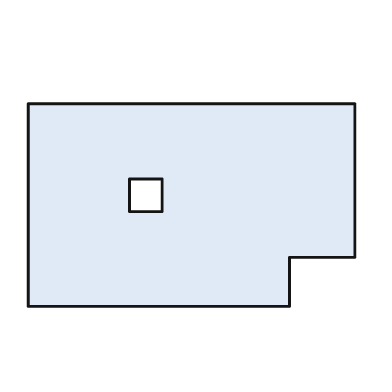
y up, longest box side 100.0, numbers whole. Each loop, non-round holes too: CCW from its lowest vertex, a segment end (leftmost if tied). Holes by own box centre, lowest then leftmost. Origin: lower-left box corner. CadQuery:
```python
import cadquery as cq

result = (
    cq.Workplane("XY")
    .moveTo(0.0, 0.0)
    .lineTo(80.0, 0.0)
    .lineTo(80.0, 15.0)
    .lineTo(100.0, 15.0)
    .lineTo(100.0, 62.0)
    .lineTo(0.0, 62.0)
    .close()
    .moveTo(31.0, 29.0)
    .lineTo(41.0, 29.0)
    .lineTo(41.0, 39.0)
    .lineTo(31.0, 39.0)
    .close()
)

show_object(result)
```